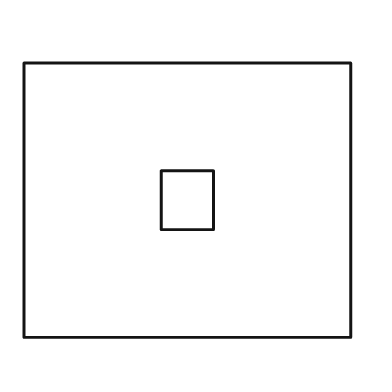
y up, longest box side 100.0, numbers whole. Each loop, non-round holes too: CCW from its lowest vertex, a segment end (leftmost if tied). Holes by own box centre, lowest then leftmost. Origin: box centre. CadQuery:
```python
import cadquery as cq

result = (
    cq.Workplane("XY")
    .moveTo(-50.0, -42.0)
    .lineTo(50.0, -42.0)
    .lineTo(50.0, 42.0)
    .lineTo(-50.0, 42.0)
    .close()
    .moveTo(-8.0, -9.0)
    .lineTo(8.0, -9.0)
    .lineTo(8.0, 9.0)
    .lineTo(-8.0, 9.0)
    .close()
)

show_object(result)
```